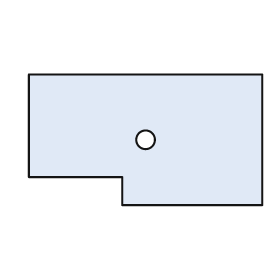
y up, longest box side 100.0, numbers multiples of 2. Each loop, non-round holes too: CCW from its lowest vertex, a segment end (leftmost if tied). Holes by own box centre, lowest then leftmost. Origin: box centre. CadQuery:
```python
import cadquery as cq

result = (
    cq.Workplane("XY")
    .moveTo(-10.0, -28.0)
    .lineTo(50.0, -28.0)
    .lineTo(50.0, 28.0)
    .lineTo(-50.0, 28.0)
    .lineTo(-50.0, -16.0)
    .lineTo(-10.0, -16.0)
    .close()
    .moveTo(0.0, 0.0)
    .circle(4.0)
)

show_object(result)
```